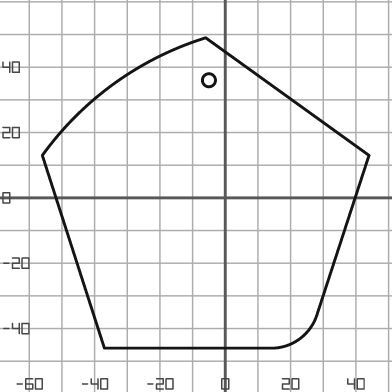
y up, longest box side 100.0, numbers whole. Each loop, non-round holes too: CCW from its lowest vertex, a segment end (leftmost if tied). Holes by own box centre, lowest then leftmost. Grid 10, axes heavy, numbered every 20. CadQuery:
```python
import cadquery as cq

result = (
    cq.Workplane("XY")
    .moveTo(-37.0, -46.0)
    .lineTo(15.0, -46.0)
    .threePointArc((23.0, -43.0), (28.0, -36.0))
    .lineTo(44.0, 13.0)
    .lineTo(-6.0, 49.0)
    .threePointArc((-34.0, 35.0), (-56.0, 13.0))
    .close()
    .moveTo(-5.0, 36.0)
    .circle(2.0)
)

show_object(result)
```